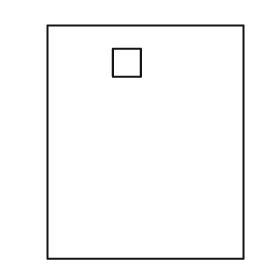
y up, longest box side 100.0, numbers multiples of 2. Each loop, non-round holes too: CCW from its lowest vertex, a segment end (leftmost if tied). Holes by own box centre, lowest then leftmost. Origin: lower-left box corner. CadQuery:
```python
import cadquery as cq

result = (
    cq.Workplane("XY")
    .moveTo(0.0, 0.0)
    .lineTo(84.0, 0.0)
    .lineTo(84.0, 100.0)
    .lineTo(0.0, 100.0)
    .close()
    .moveTo(28.0, 78.0)
    .lineTo(40.0, 78.0)
    .lineTo(40.0, 90.0)
    .lineTo(28.0, 90.0)
    .close()
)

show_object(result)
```